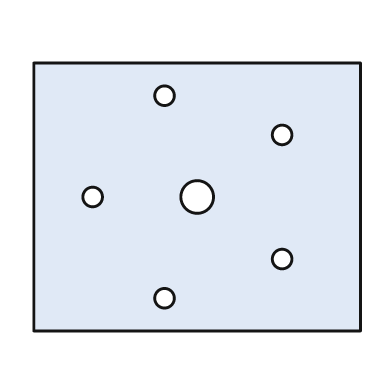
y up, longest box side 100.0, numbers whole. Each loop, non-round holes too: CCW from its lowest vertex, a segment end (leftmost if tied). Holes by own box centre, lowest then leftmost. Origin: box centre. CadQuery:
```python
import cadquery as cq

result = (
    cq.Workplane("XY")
    .moveTo(-50.0, -41.0)
    .lineTo(50.0, -41.0)
    .lineTo(50.0, 41.0)
    .lineTo(-50.0, 41.0)
    .close()
    .moveTo(-10.0, -31.0)
    .circle(3.0)
    .moveTo(26.0, -19.0)
    .circle(3.0)
    .moveTo(-32.0, 0.0)
    .circle(3.0)
    .moveTo(0.0, 0.0)
    .circle(5.0)
    .moveTo(26.0, 19.0)
    .circle(3.0)
    .moveTo(-10.0, 31.0)
    .circle(3.0)
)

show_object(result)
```